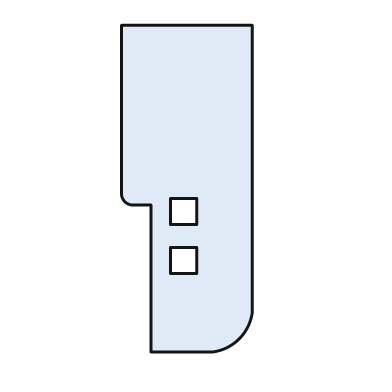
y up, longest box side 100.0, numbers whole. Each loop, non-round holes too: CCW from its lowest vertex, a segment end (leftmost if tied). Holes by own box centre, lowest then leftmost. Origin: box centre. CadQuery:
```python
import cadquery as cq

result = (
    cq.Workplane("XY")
    .moveTo(-11.0, -50.0)
    .lineTo(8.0, -50.0)
    .threePointArc((16.0, -46.0), (20.0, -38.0))
    .lineTo(20.0, 50.0)
    .lineTo(-20.0, 50.0)
    .lineTo(-20.0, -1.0)
    .threePointArc((-19.0, -4.0), (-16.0, -5.0))
    .lineTo(-11.0, -5.0)
    .close()
    .moveTo(-5.0, -26.0)
    .lineTo(3.0, -26.0)
    .lineTo(3.0, -18.0)
    .lineTo(-5.0, -18.0)
    .close()
    .moveTo(-5.0, -11.0)
    .lineTo(3.0, -11.0)
    .lineTo(3.0, -3.0)
    .lineTo(-5.0, -3.0)
    .close()
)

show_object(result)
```